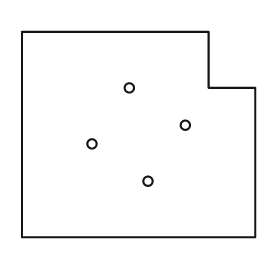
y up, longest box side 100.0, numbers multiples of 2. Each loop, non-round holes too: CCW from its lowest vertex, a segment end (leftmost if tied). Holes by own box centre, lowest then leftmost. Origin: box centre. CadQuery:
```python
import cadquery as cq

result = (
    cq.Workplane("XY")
    .moveTo(-50.0, -44.0)
    .lineTo(50.0, -44.0)
    .lineTo(50.0, 20.0)
    .lineTo(30.0, 20.0)
    .lineTo(30.0, 44.0)
    .lineTo(-50.0, 44.0)
    .close()
    .moveTo(4.0, -20.0)
    .circle(2.0)
    .moveTo(-20.0, -4.0)
    .circle(2.0)
    .moveTo(20.0, 4.0)
    .circle(2.0)
    .moveTo(-4.0, 20.0)
    .circle(2.0)
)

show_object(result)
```